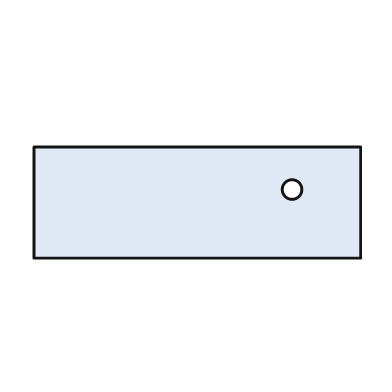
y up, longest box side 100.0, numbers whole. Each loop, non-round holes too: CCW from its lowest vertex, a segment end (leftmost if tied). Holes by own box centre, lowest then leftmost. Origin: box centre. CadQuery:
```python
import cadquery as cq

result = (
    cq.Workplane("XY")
    .moveTo(-50.0, -17.0)
    .lineTo(50.0, -17.0)
    .lineTo(50.0, 17.0)
    .lineTo(-50.0, 17.0)
    .close()
    .moveTo(29.0, 4.0)
    .circle(3.0)
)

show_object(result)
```